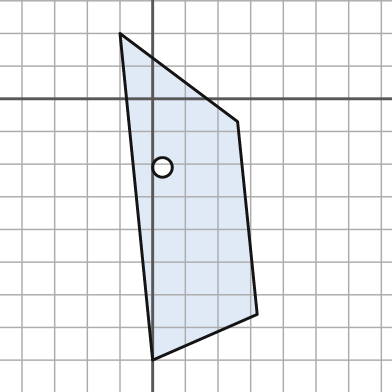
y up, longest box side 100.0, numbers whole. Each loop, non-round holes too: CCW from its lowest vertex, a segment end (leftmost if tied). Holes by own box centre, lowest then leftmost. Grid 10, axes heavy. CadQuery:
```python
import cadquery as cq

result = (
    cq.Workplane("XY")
    .moveTo(0.0, -80.0)
    .lineTo(32.0, -66.0)
    .lineTo(26.0, -7.0)
    .lineTo(-10.0, 20.0)
    .close()
    .moveTo(3.0, -21.0)
    .circle(3.0)
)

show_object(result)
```